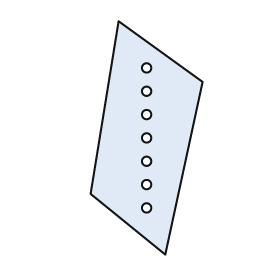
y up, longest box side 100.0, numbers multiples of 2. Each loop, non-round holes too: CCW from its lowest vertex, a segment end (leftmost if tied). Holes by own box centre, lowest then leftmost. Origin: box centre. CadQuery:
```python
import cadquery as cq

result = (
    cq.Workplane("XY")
    .moveTo(8.0, -50.0)
    .lineTo(24.0, 24.0)
    .lineTo(-12.0, 50.0)
    .lineTo(-24.0, -24.0)
    .close()
    .moveTo(0.0, -30.0)
    .circle(2.0)
    .moveTo(0.0, -20.0)
    .circle(2.0)
    .moveTo(0.0, -10.0)
    .circle(2.0)
    .moveTo(0.0, 0.0)
    .circle(2.0)
    .moveTo(0.0, 10.0)
    .circle(2.0)
    .moveTo(0.0, 20.0)
    .circle(2.0)
    .moveTo(0.0, 30.0)
    .circle(2.0)
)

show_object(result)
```